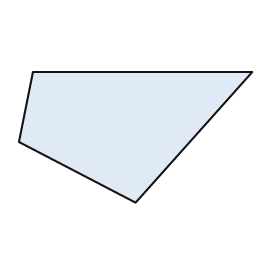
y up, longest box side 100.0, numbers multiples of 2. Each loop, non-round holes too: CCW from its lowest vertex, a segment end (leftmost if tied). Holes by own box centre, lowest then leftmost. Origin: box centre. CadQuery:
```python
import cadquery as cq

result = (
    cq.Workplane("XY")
    .moveTo(0.0, -28.0)
    .lineTo(50.0, 28.0)
    .lineTo(-44.0, 28.0)
    .lineTo(-50.0, -2.0)
    .close()
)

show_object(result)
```